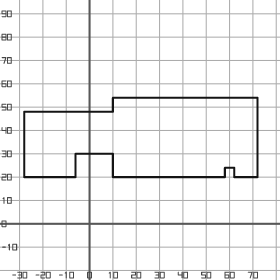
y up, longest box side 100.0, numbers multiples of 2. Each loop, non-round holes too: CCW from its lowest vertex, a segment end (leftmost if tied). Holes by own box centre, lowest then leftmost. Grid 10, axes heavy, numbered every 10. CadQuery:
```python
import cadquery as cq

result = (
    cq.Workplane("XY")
    .moveTo(-28.0, 20.0)
    .lineTo(-6.0, 20.0)
    .lineTo(-6.0, 30.0)
    .lineTo(10.0, 30.0)
    .lineTo(10.0, 20.0)
    .lineTo(58.0, 20.0)
    .lineTo(58.0, 24.0)
    .lineTo(62.0, 24.0)
    .lineTo(62.0, 20.0)
    .lineTo(72.0, 20.0)
    .lineTo(72.0, 54.0)
    .lineTo(10.0, 54.0)
    .lineTo(10.0, 48.0)
    .lineTo(-28.0, 48.0)
    .close()
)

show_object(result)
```